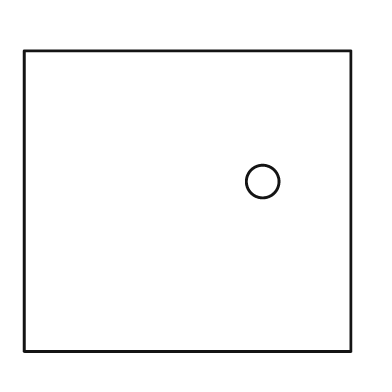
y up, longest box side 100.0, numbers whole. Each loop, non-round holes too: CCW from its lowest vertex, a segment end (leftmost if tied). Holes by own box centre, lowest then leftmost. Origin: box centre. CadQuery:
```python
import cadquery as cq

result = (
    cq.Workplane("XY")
    .moveTo(-50.0, -46.0)
    .lineTo(50.0, -46.0)
    .lineTo(50.0, 46.0)
    .lineTo(-50.0, 46.0)
    .close()
    .moveTo(23.0, 6.0)
    .circle(5.0)
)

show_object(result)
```